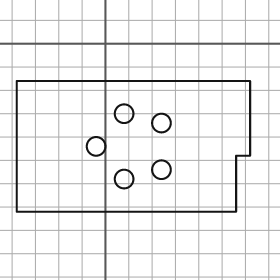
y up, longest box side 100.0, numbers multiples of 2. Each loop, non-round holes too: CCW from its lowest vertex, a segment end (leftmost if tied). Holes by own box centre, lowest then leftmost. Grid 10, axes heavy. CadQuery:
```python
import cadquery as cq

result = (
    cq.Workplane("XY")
    .moveTo(-38.0, -72.0)
    .lineTo(56.0, -72.0)
    .lineTo(56.0, -48.0)
    .lineTo(62.0, -48.0)
    .lineTo(62.0, -16.0)
    .lineTo(-38.0, -16.0)
    .close()
    .moveTo(8.0, -58.0)
    .circle(4.0)
    .moveTo(24.0, -54.0)
    .circle(4.0)
    .moveTo(-4.0, -44.0)
    .circle(4.0)
    .moveTo(24.0, -34.0)
    .circle(4.0)
    .moveTo(8.0, -30.0)
    .circle(4.0)
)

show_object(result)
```